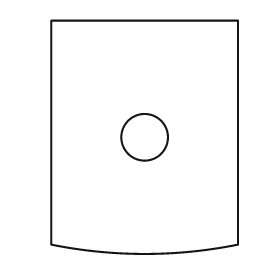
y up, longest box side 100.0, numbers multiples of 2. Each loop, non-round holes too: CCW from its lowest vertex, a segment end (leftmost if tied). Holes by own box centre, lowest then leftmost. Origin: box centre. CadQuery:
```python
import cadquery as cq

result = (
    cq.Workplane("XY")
    .moveTo(-40.0, -46.0)
    .threePointArc((0.0, -50.0), (40.0, -46.0))
    .lineTo(40.0, 50.0)
    .lineTo(-40.0, 50.0)
    .close()
    .moveTo(0.0, 0.0)
    .circle(10.0)
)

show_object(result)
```